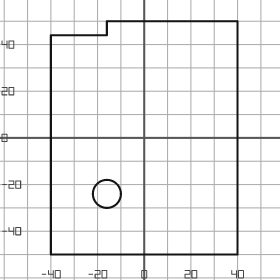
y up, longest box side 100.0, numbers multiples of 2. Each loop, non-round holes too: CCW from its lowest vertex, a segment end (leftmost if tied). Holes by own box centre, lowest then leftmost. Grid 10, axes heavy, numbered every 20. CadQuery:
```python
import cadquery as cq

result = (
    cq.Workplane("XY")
    .moveTo(-40.0, -50.0)
    .lineTo(40.0, -50.0)
    .lineTo(40.0, 50.0)
    .lineTo(-16.0, 50.0)
    .lineTo(-16.0, 44.0)
    .lineTo(-40.0, 44.0)
    .close()
    .moveTo(-16.0, -24.0)
    .circle(6.0)
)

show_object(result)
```